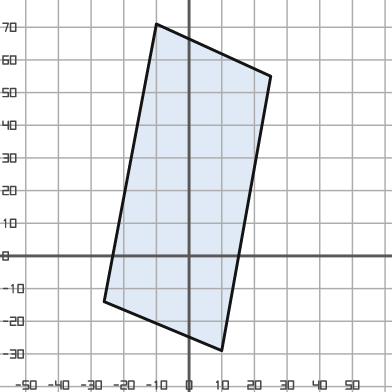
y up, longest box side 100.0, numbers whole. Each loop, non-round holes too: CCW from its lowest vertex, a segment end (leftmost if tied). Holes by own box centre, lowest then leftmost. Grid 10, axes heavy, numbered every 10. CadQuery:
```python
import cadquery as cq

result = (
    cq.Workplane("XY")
    .moveTo(10.0, -29.0)
    .lineTo(25.0, 55.0)
    .lineTo(-10.0, 71.0)
    .lineTo(-26.0, -14.0)
    .close()
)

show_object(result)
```